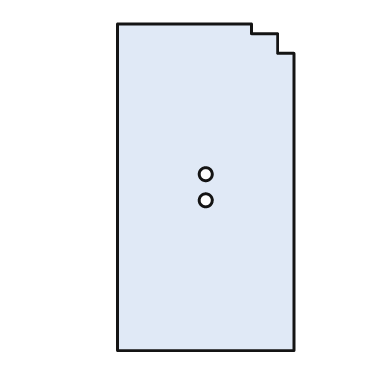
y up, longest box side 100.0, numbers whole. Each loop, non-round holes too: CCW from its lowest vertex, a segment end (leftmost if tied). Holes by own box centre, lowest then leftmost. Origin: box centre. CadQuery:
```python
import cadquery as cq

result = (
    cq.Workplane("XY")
    .moveTo(-27.0, -50.0)
    .lineTo(27.0, -50.0)
    .lineTo(27.0, 41.0)
    .lineTo(22.0, 41.0)
    .lineTo(22.0, 47.0)
    .lineTo(14.0, 47.0)
    .lineTo(14.0, 50.0)
    .lineTo(-27.0, 50.0)
    .close()
    .moveTo(0.0, -4.0)
    .circle(2.0)
    .moveTo(0.0, 4.0)
    .circle(2.0)
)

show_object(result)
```